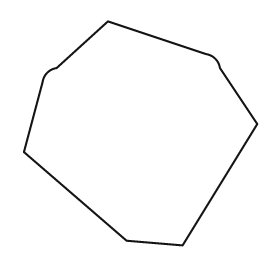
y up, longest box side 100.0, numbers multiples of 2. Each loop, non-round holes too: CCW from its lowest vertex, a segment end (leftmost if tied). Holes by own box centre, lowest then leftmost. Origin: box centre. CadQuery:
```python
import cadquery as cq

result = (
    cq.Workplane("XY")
    .moveTo(18.0, -48.0)
    .lineTo(50.0, 4.0)
    .lineTo(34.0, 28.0)
    .threePointArc((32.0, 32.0), (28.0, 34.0))
    .lineTo(-14.0, 48.0)
    .lineTo(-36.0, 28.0)
    .threePointArc((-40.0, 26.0), (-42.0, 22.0))
    .lineTo(-50.0, -8.0)
    .lineTo(-6.0, -46.0)
    .close()
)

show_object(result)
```